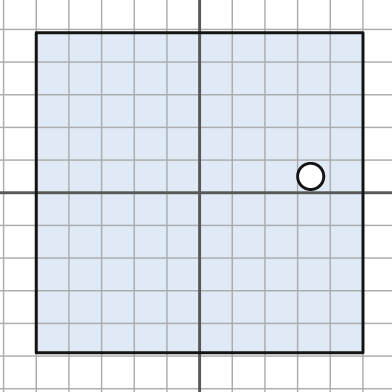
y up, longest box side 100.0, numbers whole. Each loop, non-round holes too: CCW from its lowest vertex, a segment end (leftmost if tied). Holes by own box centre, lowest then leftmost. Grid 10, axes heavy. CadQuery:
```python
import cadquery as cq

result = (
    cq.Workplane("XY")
    .moveTo(-50.0, -49.0)
    .lineTo(50.0, -49.0)
    .lineTo(50.0, 49.0)
    .lineTo(-50.0, 49.0)
    .close()
    .moveTo(34.0, 5.0)
    .circle(4.0)
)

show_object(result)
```